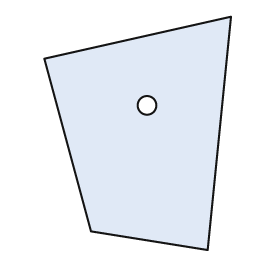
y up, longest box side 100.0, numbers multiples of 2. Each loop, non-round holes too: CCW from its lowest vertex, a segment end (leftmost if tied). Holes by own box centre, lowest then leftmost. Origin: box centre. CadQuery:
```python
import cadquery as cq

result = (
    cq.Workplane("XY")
    .moveTo(30.0, -50.0)
    .lineTo(40.0, 50.0)
    .lineTo(-40.0, 32.0)
    .lineTo(-20.0, -42.0)
    .close()
    .moveTo(4.0, 12.0)
    .circle(4.0)
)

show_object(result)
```